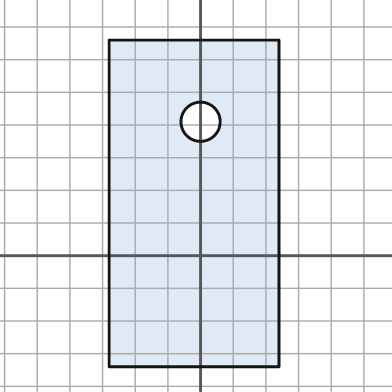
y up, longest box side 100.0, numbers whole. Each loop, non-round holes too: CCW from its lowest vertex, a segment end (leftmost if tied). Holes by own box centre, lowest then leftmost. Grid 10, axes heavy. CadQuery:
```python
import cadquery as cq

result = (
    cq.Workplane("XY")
    .moveTo(-28.0, -34.0)
    .lineTo(24.0, -34.0)
    .lineTo(24.0, 66.0)
    .lineTo(-28.0, 66.0)
    .close()
    .moveTo(0.0, 41.0)
    .circle(6.0)
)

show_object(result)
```